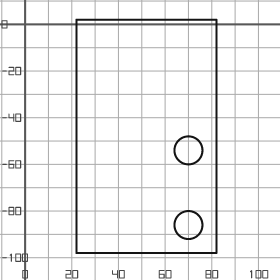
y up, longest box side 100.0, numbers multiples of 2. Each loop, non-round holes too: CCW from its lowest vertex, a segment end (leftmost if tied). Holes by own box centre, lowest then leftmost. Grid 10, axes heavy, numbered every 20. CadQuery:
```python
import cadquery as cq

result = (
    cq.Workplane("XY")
    .moveTo(22.0, -98.0)
    .lineTo(82.0, -98.0)
    .lineTo(82.0, 2.0)
    .lineTo(22.0, 2.0)
    .close()
    .moveTo(70.0, -86.0)
    .circle(6.0)
    .moveTo(70.0, -54.0)
    .circle(6.0)
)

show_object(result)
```